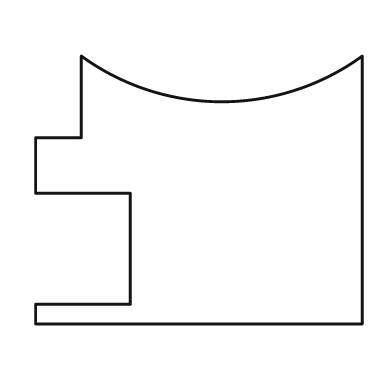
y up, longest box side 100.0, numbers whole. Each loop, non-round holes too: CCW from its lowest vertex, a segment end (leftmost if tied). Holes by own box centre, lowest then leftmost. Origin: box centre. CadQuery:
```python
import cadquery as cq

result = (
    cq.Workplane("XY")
    .moveTo(-50.0, -41.0)
    .lineTo(50.0, -41.0)
    .lineTo(50.0, 41.0)
    .threePointArc((7.0, 27.0), (-36.0, 41.0))
    .lineTo(-36.0, 16.0)
    .lineTo(-50.0, 16.0)
    .lineTo(-50.0, -1.0)
    .lineTo(-21.0, -1.0)
    .lineTo(-21.0, -35.0)
    .lineTo(-50.0, -35.0)
    .close()
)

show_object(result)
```